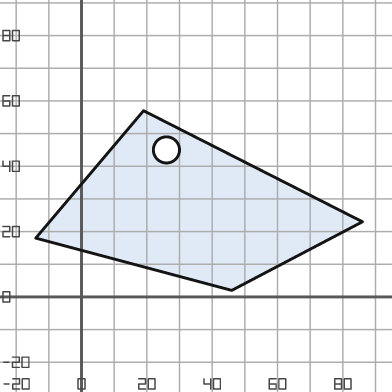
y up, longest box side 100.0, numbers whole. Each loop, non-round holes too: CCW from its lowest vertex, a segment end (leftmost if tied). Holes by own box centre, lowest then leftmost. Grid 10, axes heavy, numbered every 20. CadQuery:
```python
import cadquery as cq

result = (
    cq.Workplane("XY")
    .moveTo(46.0, 2.0)
    .lineTo(86.0, 23.0)
    .lineTo(19.0, 57.0)
    .lineTo(-14.0, 18.0)
    .close()
    .moveTo(26.0, 45.0)
    .circle(4.0)
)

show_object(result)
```